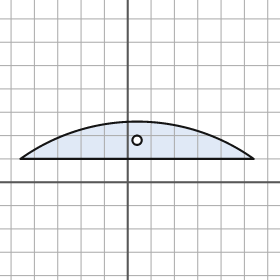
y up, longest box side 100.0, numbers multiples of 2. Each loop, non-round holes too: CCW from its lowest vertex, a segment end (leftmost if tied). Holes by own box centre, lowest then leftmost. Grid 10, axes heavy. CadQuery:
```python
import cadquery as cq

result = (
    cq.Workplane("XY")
    .moveTo(-46.0, 10.0)
    .lineTo(54.0, 10.0)
    .threePointArc((4.0, 26.0), (-46.0, 10.0))
    .close()
    .moveTo(4.0, 18.0)
    .circle(2.0)
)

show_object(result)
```